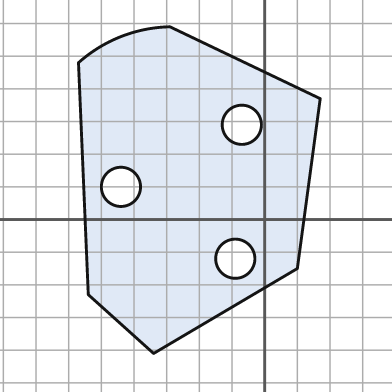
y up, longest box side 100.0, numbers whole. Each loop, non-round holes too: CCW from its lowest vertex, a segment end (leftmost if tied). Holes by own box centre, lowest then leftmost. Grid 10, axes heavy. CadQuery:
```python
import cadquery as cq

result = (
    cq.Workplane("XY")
    .moveTo(-34.0, -41.0)
    .lineTo(10.0, -15.0)
    .lineTo(17.0, 37.0)
    .lineTo(-29.0, 59.0)
    .threePointArc((-44.0, 56.0), (-57.0, 48.0))
    .lineTo(-54.0, -23.0)
    .close()
    .moveTo(-9.0, -12.0)
    .circle(6.0)
    .moveTo(-44.0, 10.0)
    .circle(6.0)
    .moveTo(-7.0, 29.0)
    .circle(6.0)
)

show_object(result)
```